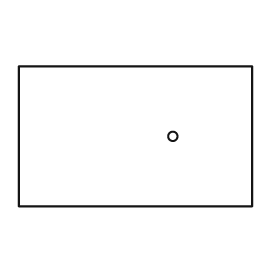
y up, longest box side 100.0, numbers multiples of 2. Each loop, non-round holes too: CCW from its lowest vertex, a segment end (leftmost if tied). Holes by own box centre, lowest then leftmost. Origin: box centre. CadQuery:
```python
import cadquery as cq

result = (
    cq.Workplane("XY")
    .moveTo(-50.0, -30.0)
    .lineTo(50.0, -30.0)
    .lineTo(50.0, 30.0)
    .lineTo(-50.0, 30.0)
    .close()
    .moveTo(16.0, 0.0)
    .circle(2.0)
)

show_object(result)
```